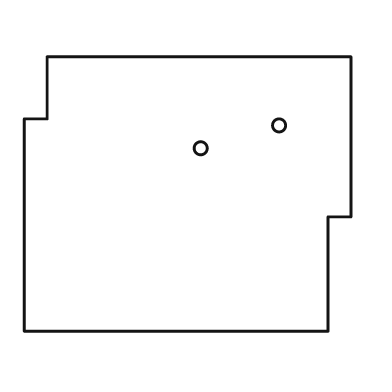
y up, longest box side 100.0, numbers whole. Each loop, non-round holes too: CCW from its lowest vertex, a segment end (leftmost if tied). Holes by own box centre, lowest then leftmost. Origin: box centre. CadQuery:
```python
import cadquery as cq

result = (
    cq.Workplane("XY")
    .moveTo(-50.0, -42.0)
    .lineTo(43.0, -42.0)
    .lineTo(43.0, -7.0)
    .lineTo(50.0, -7.0)
    .lineTo(50.0, 42.0)
    .lineTo(-43.0, 42.0)
    .lineTo(-43.0, 23.0)
    .lineTo(-50.0, 23.0)
    .close()
    .moveTo(4.0, 14.0)
    .circle(2.0)
    .moveTo(28.0, 21.0)
    .circle(2.0)
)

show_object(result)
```